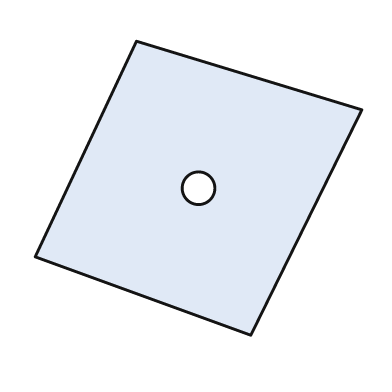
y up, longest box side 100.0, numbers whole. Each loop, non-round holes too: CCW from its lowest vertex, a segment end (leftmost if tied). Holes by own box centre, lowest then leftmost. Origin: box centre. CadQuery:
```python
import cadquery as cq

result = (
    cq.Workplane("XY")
    .moveTo(16.0, -45.0)
    .lineTo(50.0, 24.0)
    .lineTo(-19.0, 45.0)
    .lineTo(-50.0, -21.0)
    .close()
    .moveTo(0.0, 0.0)
    .circle(5.0)
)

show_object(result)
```